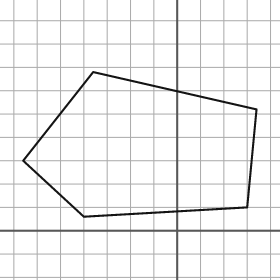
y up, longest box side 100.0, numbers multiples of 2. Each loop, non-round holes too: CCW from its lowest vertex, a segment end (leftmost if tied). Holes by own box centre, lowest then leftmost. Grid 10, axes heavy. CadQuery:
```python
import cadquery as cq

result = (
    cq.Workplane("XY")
    .moveTo(-40.0, 6.0)
    .lineTo(30.0, 10.0)
    .lineTo(34.0, 52.0)
    .lineTo(-36.0, 68.0)
    .lineTo(-66.0, 30.0)
    .close()
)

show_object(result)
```